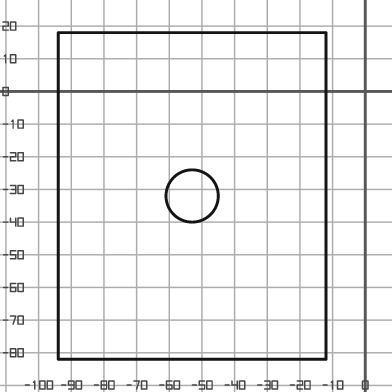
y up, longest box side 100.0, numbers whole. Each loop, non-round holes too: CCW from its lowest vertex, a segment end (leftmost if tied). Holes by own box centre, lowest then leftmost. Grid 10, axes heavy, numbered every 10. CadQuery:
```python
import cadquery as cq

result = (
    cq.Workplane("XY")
    .moveTo(-94.0, -82.0)
    .lineTo(-12.0, -82.0)
    .lineTo(-12.0, 18.0)
    .lineTo(-94.0, 18.0)
    .close()
    .moveTo(-53.0, -32.0)
    .circle(8.0)
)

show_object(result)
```